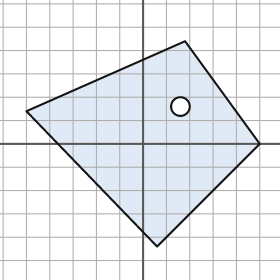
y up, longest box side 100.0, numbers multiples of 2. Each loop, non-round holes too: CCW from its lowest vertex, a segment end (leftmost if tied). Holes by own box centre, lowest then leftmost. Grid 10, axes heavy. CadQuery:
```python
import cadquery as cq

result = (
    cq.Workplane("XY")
    .moveTo(6.0, -44.0)
    .lineTo(50.0, 0.0)
    .lineTo(18.0, 44.0)
    .lineTo(-50.0, 14.0)
    .close()
    .moveTo(16.0, 16.0)
    .circle(4.0)
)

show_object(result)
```